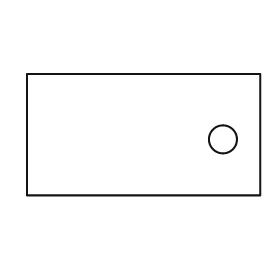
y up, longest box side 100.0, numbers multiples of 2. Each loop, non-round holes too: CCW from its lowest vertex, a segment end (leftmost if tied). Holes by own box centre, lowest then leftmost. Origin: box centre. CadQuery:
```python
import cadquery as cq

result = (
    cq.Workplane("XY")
    .moveTo(-50.0, -26.0)
    .lineTo(50.0, -26.0)
    .lineTo(50.0, 26.0)
    .lineTo(-50.0, 26.0)
    .close()
    .moveTo(34.0, -2.0)
    .circle(6.0)
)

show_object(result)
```